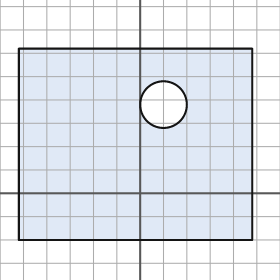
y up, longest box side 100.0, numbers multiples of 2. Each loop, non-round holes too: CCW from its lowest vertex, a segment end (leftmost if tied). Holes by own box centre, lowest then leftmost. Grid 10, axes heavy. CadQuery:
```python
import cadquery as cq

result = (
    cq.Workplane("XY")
    .moveTo(-52.0, -20.0)
    .lineTo(48.0, -20.0)
    .lineTo(48.0, 62.0)
    .lineTo(-52.0, 62.0)
    .close()
    .moveTo(10.0, 38.0)
    .circle(10.0)
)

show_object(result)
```